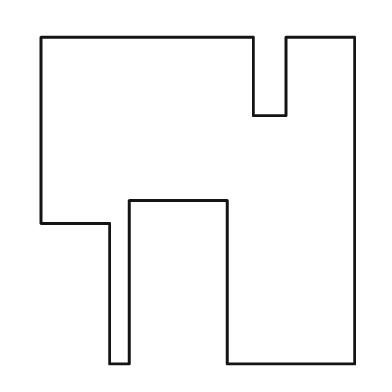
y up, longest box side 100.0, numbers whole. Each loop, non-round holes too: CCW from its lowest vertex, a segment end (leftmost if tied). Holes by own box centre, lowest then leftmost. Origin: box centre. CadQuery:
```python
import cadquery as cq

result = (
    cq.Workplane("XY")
    .moveTo(-27.0, -50.0)
    .lineTo(-21.0, -50.0)
    .lineTo(-21.0, 0.0)
    .lineTo(9.0, 0.0)
    .lineTo(9.0, -50.0)
    .lineTo(48.0, -50.0)
    .lineTo(48.0, 50.0)
    .lineTo(27.0, 50.0)
    .lineTo(27.0, 26.0)
    .lineTo(17.0, 26.0)
    .lineTo(17.0, 50.0)
    .lineTo(-48.0, 50.0)
    .lineTo(-48.0, -7.0)
    .lineTo(-27.0, -7.0)
    .close()
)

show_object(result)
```